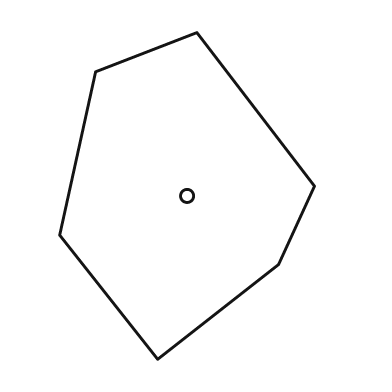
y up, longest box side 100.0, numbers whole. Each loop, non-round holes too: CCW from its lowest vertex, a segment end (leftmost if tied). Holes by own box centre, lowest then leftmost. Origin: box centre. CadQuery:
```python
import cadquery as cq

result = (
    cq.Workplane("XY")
    .moveTo(-9.0, -50.0)
    .lineTo(28.0, -21.0)
    .lineTo(39.0, 3.0)
    .lineTo(3.0, 50.0)
    .lineTo(-28.0, 38.0)
    .lineTo(-39.0, -12.0)
    .close()
    .moveTo(0.0, 0.0)
    .circle(2.0)
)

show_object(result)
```